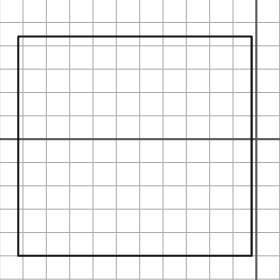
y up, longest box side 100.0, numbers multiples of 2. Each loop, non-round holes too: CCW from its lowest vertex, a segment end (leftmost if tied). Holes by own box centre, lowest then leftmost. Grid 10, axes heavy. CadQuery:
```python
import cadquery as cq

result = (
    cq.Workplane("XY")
    .moveTo(-102.0, -50.0)
    .lineTo(-2.0, -50.0)
    .lineTo(-2.0, 44.0)
    .lineTo(-102.0, 44.0)
    .close()
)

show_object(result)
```